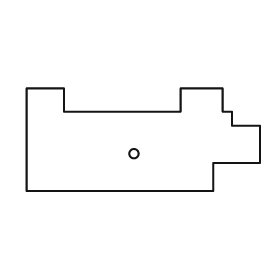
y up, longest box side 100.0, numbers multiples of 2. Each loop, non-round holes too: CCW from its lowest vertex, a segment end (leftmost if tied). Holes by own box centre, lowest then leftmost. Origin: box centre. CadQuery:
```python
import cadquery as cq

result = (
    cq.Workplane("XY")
    .moveTo(-50.0, -22.0)
    .lineTo(30.0, -22.0)
    .lineTo(30.0, -10.0)
    .lineTo(50.0, -10.0)
    .lineTo(50.0, 6.0)
    .lineTo(38.0, 6.0)
    .lineTo(38.0, 12.0)
    .lineTo(34.0, 12.0)
    .lineTo(34.0, 22.0)
    .lineTo(16.0, 22.0)
    .lineTo(16.0, 12.0)
    .lineTo(-34.0, 12.0)
    .lineTo(-34.0, 22.0)
    .lineTo(-50.0, 22.0)
    .close()
    .moveTo(-4.0, -6.0)
    .circle(2.0)
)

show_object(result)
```